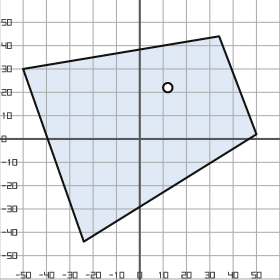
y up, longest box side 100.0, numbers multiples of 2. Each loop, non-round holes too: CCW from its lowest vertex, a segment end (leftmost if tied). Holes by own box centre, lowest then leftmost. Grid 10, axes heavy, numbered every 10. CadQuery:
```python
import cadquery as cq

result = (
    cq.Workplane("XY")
    .moveTo(-24.0, -44.0)
    .lineTo(50.0, 2.0)
    .lineTo(34.0, 44.0)
    .lineTo(-50.0, 30.0)
    .close()
    .moveTo(12.0, 22.0)
    .circle(2.0)
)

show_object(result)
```